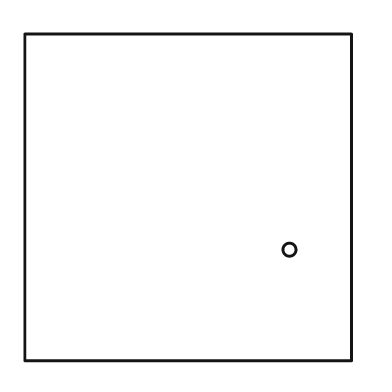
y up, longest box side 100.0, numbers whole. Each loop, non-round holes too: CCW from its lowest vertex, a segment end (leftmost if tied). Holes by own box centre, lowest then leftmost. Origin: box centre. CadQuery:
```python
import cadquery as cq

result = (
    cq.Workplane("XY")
    .moveTo(-50.0, -50.0)
    .lineTo(50.0, -50.0)
    .lineTo(50.0, 50.0)
    .lineTo(-50.0, 50.0)
    .close()
    .moveTo(31.0, -16.0)
    .circle(2.0)
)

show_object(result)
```